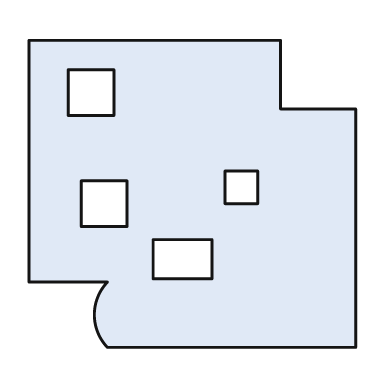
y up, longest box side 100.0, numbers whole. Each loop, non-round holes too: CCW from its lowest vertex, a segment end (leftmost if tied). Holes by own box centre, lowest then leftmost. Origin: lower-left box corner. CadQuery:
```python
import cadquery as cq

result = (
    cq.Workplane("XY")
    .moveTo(24.0, 0.0)
    .lineTo(100.0, 0.0)
    .lineTo(100.0, 73.0)
    .lineTo(77.0, 73.0)
    .lineTo(77.0, 94.0)
    .lineTo(0.0, 94.0)
    .lineTo(0.0, 20.0)
    .lineTo(24.0, 20.0)
    .threePointArc((20.0, 10.0), (24.0, 0.0))
    .close()
    .moveTo(38.0, 21.0)
    .lineTo(56.0, 21.0)
    .lineTo(56.0, 33.0)
    .lineTo(38.0, 33.0)
    .close()
    .moveTo(16.0, 37.0)
    .lineTo(30.0, 37.0)
    .lineTo(30.0, 51.0)
    .lineTo(16.0, 51.0)
    .close()
    .moveTo(60.0, 44.0)
    .lineTo(70.0, 44.0)
    .lineTo(70.0, 54.0)
    .lineTo(60.0, 54.0)
    .close()
    .moveTo(12.0, 71.0)
    .lineTo(26.0, 71.0)
    .lineTo(26.0, 85.0)
    .lineTo(12.0, 85.0)
    .close()
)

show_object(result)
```